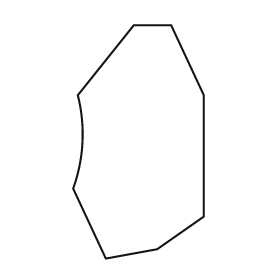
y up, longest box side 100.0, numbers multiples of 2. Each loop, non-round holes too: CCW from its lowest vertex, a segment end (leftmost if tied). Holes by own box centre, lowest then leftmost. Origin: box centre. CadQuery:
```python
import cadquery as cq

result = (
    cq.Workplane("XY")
    .moveTo(-14.0, -50.0)
    .lineTo(8.0, -46.0)
    .lineTo(28.0, -32.0)
    .lineTo(28.0, 20.0)
    .lineTo(14.0, 50.0)
    .lineTo(-2.0, 50.0)
    .lineTo(-26.0, 20.0)
    .threePointArc((-24.0, 0.0), (-28.0, -20.0))
    .close()
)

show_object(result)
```